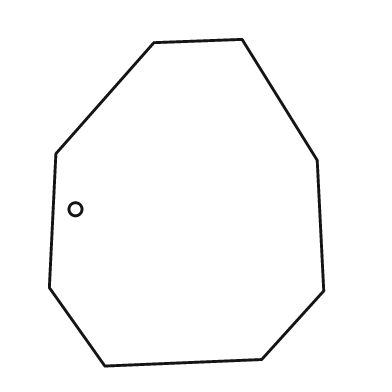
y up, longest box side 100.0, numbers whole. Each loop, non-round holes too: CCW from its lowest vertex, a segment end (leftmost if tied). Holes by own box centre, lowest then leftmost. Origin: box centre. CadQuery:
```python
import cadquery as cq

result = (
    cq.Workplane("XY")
    .moveTo(-25.0, -50.0)
    .lineTo(23.0, -48.0)
    .lineTo(42.0, -27.0)
    .lineTo(40.0, 13.0)
    .lineTo(17.0, 50.0)
    .lineTo(-10.0, 49.0)
    .lineTo(-40.0, 15.0)
    .lineTo(-42.0, -26.0)
    .close()
    .moveTo(-34.0, -2.0)
    .circle(2.0)
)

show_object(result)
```